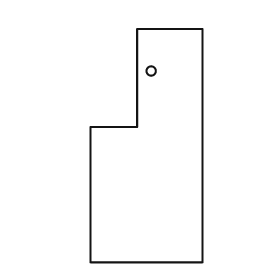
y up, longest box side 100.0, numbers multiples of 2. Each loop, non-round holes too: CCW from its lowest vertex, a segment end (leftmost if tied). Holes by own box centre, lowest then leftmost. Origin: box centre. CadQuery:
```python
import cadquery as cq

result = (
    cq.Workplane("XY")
    .moveTo(-24.0, -50.0)
    .lineTo(24.0, -50.0)
    .lineTo(24.0, 50.0)
    .lineTo(-4.0, 50.0)
    .lineTo(-4.0, 8.0)
    .lineTo(-24.0, 8.0)
    .close()
    .moveTo(2.0, 32.0)
    .circle(2.0)
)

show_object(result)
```